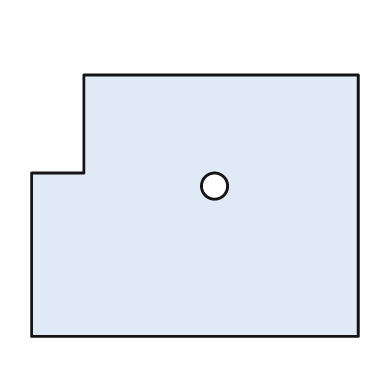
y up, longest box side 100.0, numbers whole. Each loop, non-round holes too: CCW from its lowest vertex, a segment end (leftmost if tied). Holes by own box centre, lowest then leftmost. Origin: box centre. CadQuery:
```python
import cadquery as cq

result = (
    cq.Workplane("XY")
    .moveTo(-50.0, -40.0)
    .lineTo(50.0, -40.0)
    .lineTo(50.0, 40.0)
    .lineTo(-34.0, 40.0)
    .lineTo(-34.0, 10.0)
    .lineTo(-50.0, 10.0)
    .close()
    .moveTo(6.0, 6.0)
    .circle(4.0)
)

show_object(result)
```